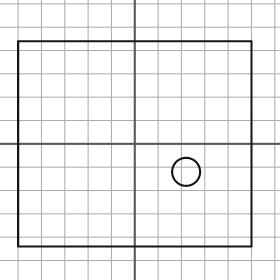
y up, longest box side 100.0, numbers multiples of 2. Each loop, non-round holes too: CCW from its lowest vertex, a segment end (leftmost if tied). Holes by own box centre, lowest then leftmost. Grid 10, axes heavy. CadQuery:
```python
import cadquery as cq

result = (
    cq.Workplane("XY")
    .moveTo(-50.0, -44.0)
    .lineTo(50.0, -44.0)
    .lineTo(50.0, 44.0)
    .lineTo(-50.0, 44.0)
    .close()
    .moveTo(22.0, -12.0)
    .circle(6.0)
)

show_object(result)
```